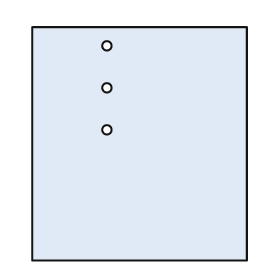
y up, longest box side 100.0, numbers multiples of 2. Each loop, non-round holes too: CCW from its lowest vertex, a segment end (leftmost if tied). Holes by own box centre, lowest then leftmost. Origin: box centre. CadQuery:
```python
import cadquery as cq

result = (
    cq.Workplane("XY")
    .moveTo(-46.0, -50.0)
    .lineTo(46.0, -50.0)
    .lineTo(46.0, 50.0)
    .lineTo(-46.0, 50.0)
    .close()
    .moveTo(-14.0, 6.0)
    .circle(2.0)
    .moveTo(-14.0, 24.0)
    .circle(2.0)
    .moveTo(-14.0, 42.0)
    .circle(2.0)
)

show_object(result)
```